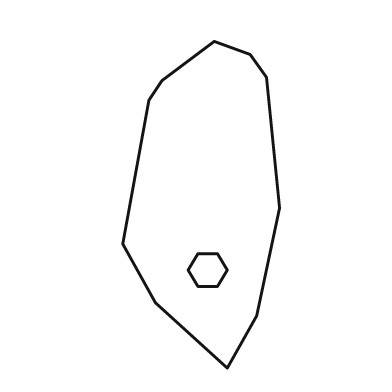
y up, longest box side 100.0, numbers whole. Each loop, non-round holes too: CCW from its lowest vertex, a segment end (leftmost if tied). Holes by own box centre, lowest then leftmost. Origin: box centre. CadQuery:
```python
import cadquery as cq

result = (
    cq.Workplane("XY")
    .moveTo(8.0, -50.0)
    .lineTo(17.0, -34.0)
    .lineTo(24.0, -1.0)
    .lineTo(20.0, 39.0)
    .lineTo(15.0, 46.0)
    .lineTo(4.0, 50.0)
    .lineTo(-12.0, 38.0)
    .lineTo(-16.0, 32.0)
    .lineTo(-24.0, -12.0)
    .lineTo(-14.0, -30.0)
    .close()
    .moveTo(-1.0, -25.0)
    .lineTo(5.0, -25.0)
    .lineTo(8.0, -20.0)
    .lineTo(5.0, -15.0)
    .lineTo(-1.0, -15.0)
    .lineTo(-4.0, -20.0)
    .close()
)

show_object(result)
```